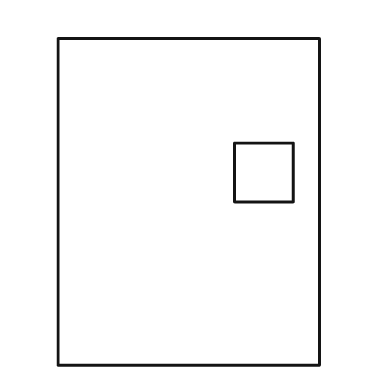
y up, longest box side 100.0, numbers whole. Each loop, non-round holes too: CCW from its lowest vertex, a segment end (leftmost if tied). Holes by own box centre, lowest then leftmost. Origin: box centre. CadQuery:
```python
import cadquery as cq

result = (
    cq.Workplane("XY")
    .moveTo(-40.0, -50.0)
    .lineTo(40.0, -50.0)
    .lineTo(40.0, 50.0)
    .lineTo(-40.0, 50.0)
    .close()
    .moveTo(14.0, 0.0)
    .lineTo(32.0, 0.0)
    .lineTo(32.0, 18.0)
    .lineTo(14.0, 18.0)
    .close()
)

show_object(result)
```